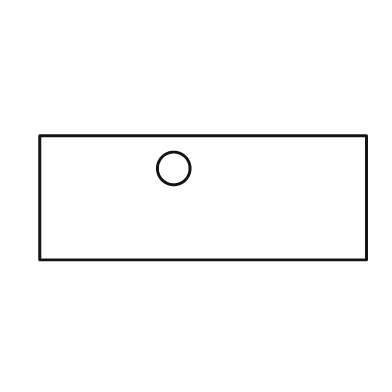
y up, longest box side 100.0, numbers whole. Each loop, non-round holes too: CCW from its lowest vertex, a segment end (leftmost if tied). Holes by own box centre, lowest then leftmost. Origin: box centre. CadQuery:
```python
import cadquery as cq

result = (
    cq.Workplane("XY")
    .moveTo(-50.0, -19.0)
    .lineTo(50.0, -19.0)
    .lineTo(50.0, 19.0)
    .lineTo(-50.0, 19.0)
    .close()
    .moveTo(-9.0, 9.0)
    .circle(5.0)
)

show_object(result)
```